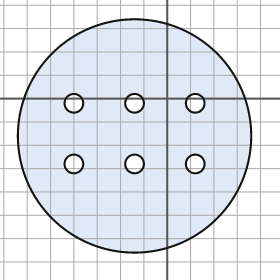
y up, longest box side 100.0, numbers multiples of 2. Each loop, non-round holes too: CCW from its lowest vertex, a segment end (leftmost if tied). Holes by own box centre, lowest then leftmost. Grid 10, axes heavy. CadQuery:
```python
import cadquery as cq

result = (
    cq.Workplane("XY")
    .moveTo(-14.0, -16.0)
    .circle(50.0)
    .moveTo(-40.0, -28.0)
    .circle(4.0)
    .moveTo(-14.0, -28.0)
    .circle(4.0)
    .moveTo(12.0, -28.0)
    .circle(4.0)
    .moveTo(-40.0, -2.0)
    .circle(4.0)
    .moveTo(-14.0, -2.0)
    .circle(4.0)
    .moveTo(12.0, -2.0)
    .circle(4.0)
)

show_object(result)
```